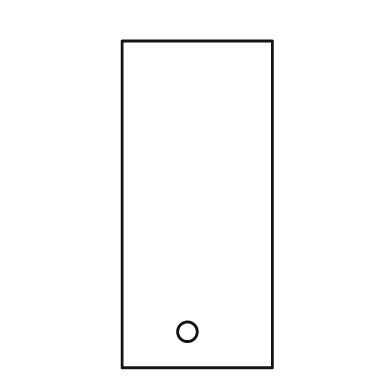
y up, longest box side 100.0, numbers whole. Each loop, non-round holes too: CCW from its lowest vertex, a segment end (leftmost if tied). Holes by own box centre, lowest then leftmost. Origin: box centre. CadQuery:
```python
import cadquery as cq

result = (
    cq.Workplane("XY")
    .moveTo(-23.0, -50.0)
    .lineTo(23.0, -50.0)
    .lineTo(23.0, 50.0)
    .lineTo(-23.0, 50.0)
    .close()
    .moveTo(-3.0, -39.0)
    .circle(3.0)
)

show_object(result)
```